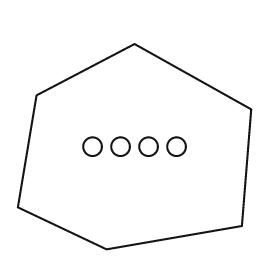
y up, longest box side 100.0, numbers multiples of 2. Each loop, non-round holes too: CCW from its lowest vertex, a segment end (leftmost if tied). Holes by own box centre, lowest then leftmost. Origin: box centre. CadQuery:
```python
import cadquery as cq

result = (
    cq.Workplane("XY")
    .moveTo(-12.0, -44.0)
    .lineTo(46.0, -34.0)
    .lineTo(50.0, 16.0)
    .lineTo(0.0, 44.0)
    .lineTo(-42.0, 22.0)
    .lineTo(-50.0, -26.0)
    .close()
    .moveTo(-18.0, 0.0)
    .circle(4.0)
    .moveTo(-6.0, 0.0)
    .circle(4.0)
    .moveTo(6.0, 0.0)
    .circle(4.0)
    .moveTo(18.0, 0.0)
    .circle(4.0)
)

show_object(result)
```